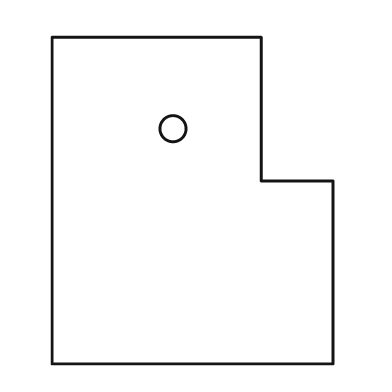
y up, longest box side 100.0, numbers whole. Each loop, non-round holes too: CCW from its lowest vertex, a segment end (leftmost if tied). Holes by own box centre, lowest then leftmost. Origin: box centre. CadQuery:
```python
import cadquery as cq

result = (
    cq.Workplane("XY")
    .moveTo(-43.0, -50.0)
    .lineTo(43.0, -50.0)
    .lineTo(43.0, 6.0)
    .lineTo(21.0, 6.0)
    .lineTo(21.0, 50.0)
    .lineTo(-43.0, 50.0)
    .close()
    .moveTo(-6.0, 22.0)
    .circle(4.0)
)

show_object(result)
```